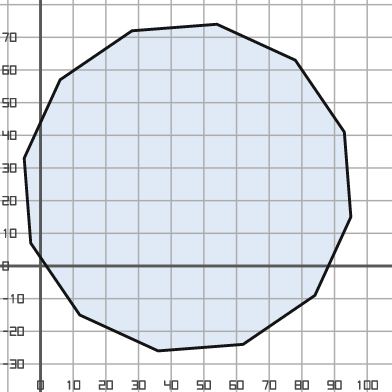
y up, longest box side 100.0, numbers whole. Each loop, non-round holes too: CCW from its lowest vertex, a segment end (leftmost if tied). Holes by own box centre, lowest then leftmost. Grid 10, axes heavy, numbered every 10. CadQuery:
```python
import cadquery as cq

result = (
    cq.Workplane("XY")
    .moveTo(36.0, -26.0)
    .lineTo(62.0, -24.0)
    .lineTo(84.0, -9.0)
    .lineTo(95.0, 15.0)
    .lineTo(93.0, 41.0)
    .lineTo(78.0, 63.0)
    .lineTo(54.0, 74.0)
    .lineTo(28.0, 72.0)
    .lineTo(6.0, 57.0)
    .lineTo(-5.0, 33.0)
    .lineTo(-3.0, 7.0)
    .lineTo(12.0, -15.0)
    .close()
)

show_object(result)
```